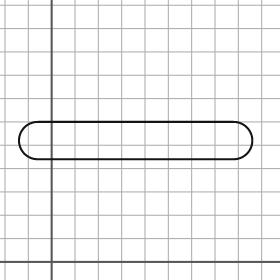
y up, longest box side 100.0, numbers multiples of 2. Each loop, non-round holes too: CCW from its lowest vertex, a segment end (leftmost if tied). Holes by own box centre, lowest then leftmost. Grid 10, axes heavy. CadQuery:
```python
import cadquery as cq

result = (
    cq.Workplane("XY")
    .moveTo(-6.0, 44.0)
    .lineTo(78.0, 44.0)
    .threePointArc((86.0, 52.0), (78.0, 60.0))
    .lineTo(-6.0, 60.0)
    .threePointArc((-14.0, 52.0), (-6.0, 44.0))
    .close()
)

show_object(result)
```